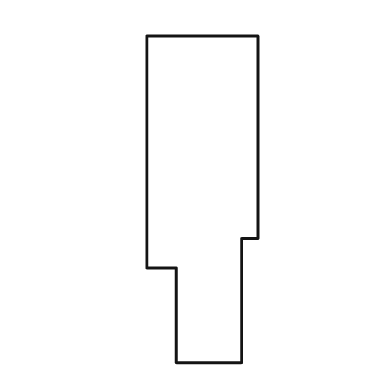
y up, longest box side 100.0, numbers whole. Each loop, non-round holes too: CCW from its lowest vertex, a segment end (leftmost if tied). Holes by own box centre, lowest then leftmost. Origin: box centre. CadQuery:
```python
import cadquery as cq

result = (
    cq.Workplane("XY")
    .moveTo(-8.0, -50.0)
    .lineTo(12.0, -50.0)
    .lineTo(12.0, -12.0)
    .lineTo(17.0, -12.0)
    .lineTo(17.0, 50.0)
    .lineTo(-17.0, 50.0)
    .lineTo(-17.0, -21.0)
    .lineTo(-8.0, -21.0)
    .close()
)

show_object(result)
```